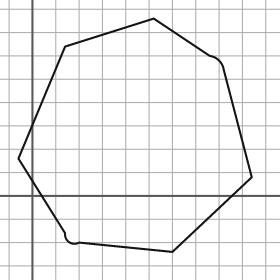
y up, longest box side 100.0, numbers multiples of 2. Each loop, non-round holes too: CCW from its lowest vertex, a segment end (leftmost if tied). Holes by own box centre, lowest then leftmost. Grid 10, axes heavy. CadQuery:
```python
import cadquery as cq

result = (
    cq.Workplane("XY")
    .moveTo(60.0, -24.0)
    .lineTo(94.0, 8.0)
    .lineTo(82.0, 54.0)
    .threePointArc((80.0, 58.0), (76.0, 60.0))
    .lineTo(52.0, 76.0)
    .lineTo(14.0, 64.0)
    .lineTo(-6.0, 16.0)
    .lineTo(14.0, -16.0)
    .threePointArc((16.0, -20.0), (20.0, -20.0))
    .close()
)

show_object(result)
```